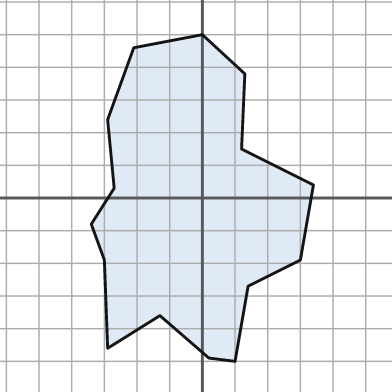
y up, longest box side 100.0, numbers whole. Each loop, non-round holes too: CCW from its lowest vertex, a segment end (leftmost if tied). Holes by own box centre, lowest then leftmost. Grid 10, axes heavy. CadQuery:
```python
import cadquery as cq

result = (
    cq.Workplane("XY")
    .moveTo(10.0, -50.0)
    .lineTo(14.0, -27.0)
    .lineTo(30.0, -19.0)
    .lineTo(34.0, 4.0)
    .lineTo(12.0, 15.0)
    .lineTo(13.0, 38.0)
    .lineTo(0.0, 50.0)
    .lineTo(-21.0, 46.0)
    .lineTo(-29.0, 24.0)
    .lineTo(-27.0, 3.0)
    .lineTo(-34.0, -8.0)
    .lineTo(-30.0, -19.0)
    .lineTo(-29.0, -46.0)
    .lineTo(-13.0, -36.0)
    .lineTo(2.0, -49.0)
    .close()
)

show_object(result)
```